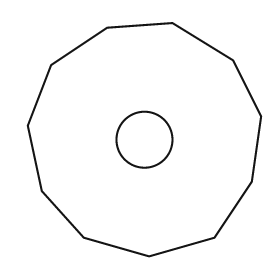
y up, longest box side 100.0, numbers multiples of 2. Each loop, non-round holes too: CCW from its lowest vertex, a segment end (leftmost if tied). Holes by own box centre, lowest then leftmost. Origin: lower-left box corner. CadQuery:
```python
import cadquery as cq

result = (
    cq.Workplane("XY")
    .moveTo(52.0, 0.0)
    .lineTo(80.0, 8.0)
    .lineTo(96.0, 32.0)
    .lineTo(100.0, 60.0)
    .lineTo(88.0, 84.0)
    .lineTo(62.0, 100.0)
    .lineTo(34.0, 98.0)
    .lineTo(10.0, 82.0)
    .lineTo(0.0, 56.0)
    .lineTo(6.0, 28.0)
    .lineTo(24.0, 8.0)
    .close()
    .moveTo(50.0, 50.0)
    .circle(12.0)
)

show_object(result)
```